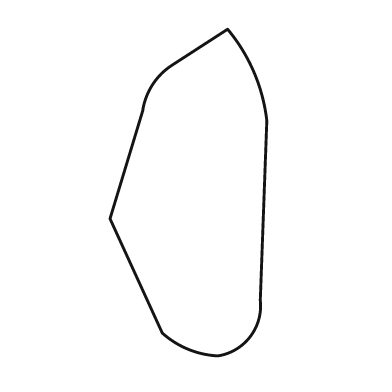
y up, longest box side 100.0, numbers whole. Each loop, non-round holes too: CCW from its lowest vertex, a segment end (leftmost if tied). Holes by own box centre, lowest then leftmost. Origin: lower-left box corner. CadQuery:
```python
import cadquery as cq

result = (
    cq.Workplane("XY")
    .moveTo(33.0, 0.0)
    .threePointArc((43.0, 6.0), (46.0, 17.0))
    .lineTo(48.0, 72.0)
    .threePointArc((44.0, 87.0), (36.0, 100.0))
    .lineTo(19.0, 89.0)
    .threePointArc((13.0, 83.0), (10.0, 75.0))
    .lineTo(0.0, 42.0)
    .lineTo(16.0, 7.0)
    .threePointArc((24.0, 2.0), (33.0, 0.0))
    .close()
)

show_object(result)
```